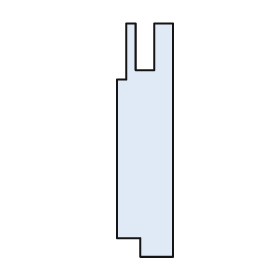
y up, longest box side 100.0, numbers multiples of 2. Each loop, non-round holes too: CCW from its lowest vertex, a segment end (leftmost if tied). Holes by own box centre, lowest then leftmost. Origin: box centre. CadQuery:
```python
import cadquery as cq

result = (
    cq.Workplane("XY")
    .moveTo(-2.0, -50.0)
    .lineTo(12.0, -50.0)
    .lineTo(12.0, 50.0)
    .lineTo(4.0, 50.0)
    .lineTo(4.0, 30.0)
    .lineTo(-4.0, 30.0)
    .lineTo(-4.0, 50.0)
    .lineTo(-8.0, 50.0)
    .lineTo(-8.0, 26.0)
    .lineTo(-12.0, 26.0)
    .lineTo(-12.0, -42.0)
    .lineTo(-2.0, -42.0)
    .close()
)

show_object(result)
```